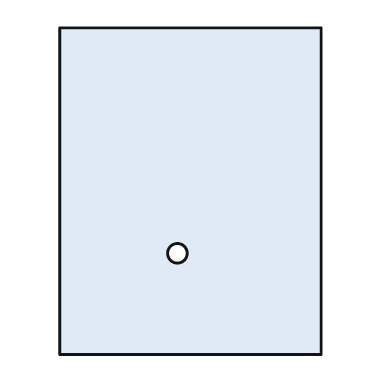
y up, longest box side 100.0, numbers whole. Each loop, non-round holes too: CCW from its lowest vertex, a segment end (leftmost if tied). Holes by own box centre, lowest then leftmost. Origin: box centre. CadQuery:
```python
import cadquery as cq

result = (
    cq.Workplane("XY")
    .moveTo(-40.0, -50.0)
    .lineTo(40.0, -50.0)
    .lineTo(40.0, 50.0)
    .lineTo(-40.0, 50.0)
    .close()
    .moveTo(-4.0, -19.0)
    .circle(3.0)
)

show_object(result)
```